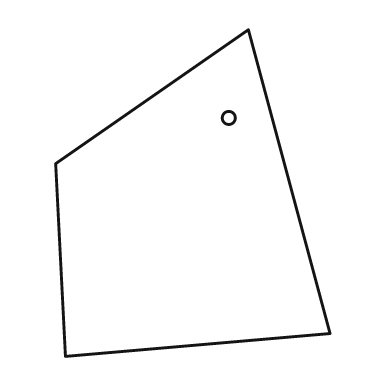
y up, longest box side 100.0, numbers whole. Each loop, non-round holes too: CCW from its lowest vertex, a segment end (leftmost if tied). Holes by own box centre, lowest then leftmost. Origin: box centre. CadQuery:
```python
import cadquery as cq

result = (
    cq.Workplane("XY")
    .moveTo(-39.0, -50.0)
    .lineTo(42.0, -43.0)
    .lineTo(17.0, 50.0)
    .lineTo(-42.0, 9.0)
    .close()
    .moveTo(11.0, 23.0)
    .circle(2.0)
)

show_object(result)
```